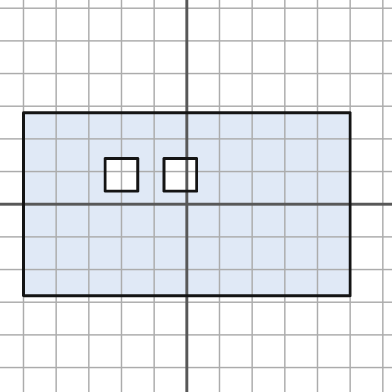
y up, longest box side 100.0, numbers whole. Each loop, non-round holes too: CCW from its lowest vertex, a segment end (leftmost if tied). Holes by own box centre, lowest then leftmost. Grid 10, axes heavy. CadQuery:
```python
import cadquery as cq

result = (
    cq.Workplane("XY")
    .moveTo(-50.0, -28.0)
    .lineTo(50.0, -28.0)
    .lineTo(50.0, 28.0)
    .lineTo(-50.0, 28.0)
    .close()
    .moveTo(-25.0, 4.0)
    .lineTo(-15.0, 4.0)
    .lineTo(-15.0, 14.0)
    .lineTo(-25.0, 14.0)
    .close()
    .moveTo(-7.0, 4.0)
    .lineTo(3.0, 4.0)
    .lineTo(3.0, 14.0)
    .lineTo(-7.0, 14.0)
    .close()
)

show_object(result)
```